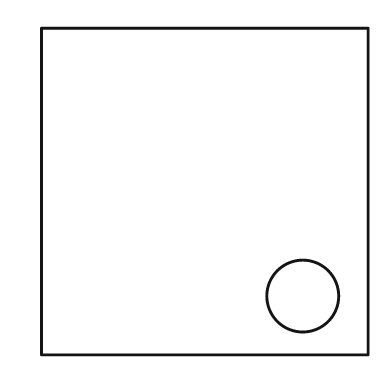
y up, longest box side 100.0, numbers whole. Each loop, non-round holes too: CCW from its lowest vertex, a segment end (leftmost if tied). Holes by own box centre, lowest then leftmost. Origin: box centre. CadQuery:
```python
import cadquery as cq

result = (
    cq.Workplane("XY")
    .moveTo(-50.0, -50.0)
    .lineTo(50.0, -50.0)
    .lineTo(50.0, 50.0)
    .lineTo(-50.0, 50.0)
    .close()
    .moveTo(30.0, -32.0)
    .circle(11.0)
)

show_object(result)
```